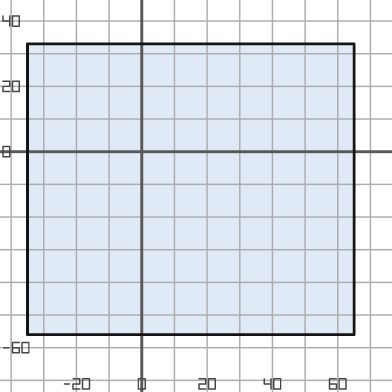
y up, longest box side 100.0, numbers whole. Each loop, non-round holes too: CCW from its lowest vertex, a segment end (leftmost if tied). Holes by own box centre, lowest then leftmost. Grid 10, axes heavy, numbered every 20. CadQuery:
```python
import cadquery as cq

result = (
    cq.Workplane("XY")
    .moveTo(-35.0, -56.0)
    .lineTo(65.0, -56.0)
    .lineTo(65.0, 33.0)
    .lineTo(-35.0, 33.0)
    .close()
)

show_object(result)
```